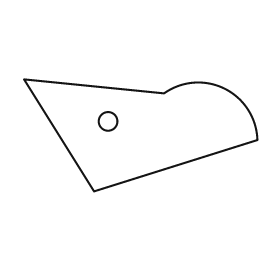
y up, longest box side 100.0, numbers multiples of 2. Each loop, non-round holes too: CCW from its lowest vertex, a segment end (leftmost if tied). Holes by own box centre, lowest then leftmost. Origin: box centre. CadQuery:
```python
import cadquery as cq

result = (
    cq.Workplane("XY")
    .moveTo(-20.0, -24.0)
    .lineTo(50.0, -2.0)
    .threePointArc((36.0, 20.0), (10.0, 18.0))
    .lineTo(-50.0, 24.0)
    .close()
    .moveTo(-14.0, 6.0)
    .circle(4.0)
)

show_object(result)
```